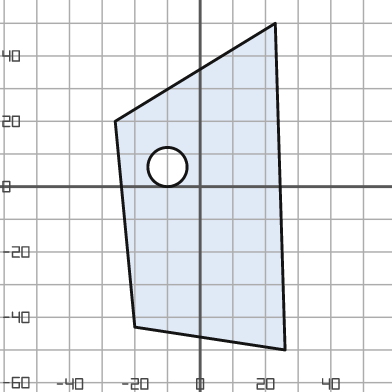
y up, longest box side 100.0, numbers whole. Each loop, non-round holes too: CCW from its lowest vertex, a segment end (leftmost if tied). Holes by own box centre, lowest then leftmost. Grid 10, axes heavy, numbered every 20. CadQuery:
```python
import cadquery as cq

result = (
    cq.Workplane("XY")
    .moveTo(26.0, -50.0)
    .lineTo(23.0, 50.0)
    .lineTo(-26.0, 20.0)
    .lineTo(-20.0, -43.0)
    .close()
    .moveTo(-10.0, 6.0)
    .circle(6.0)
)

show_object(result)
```